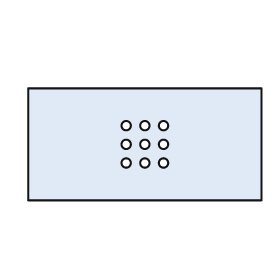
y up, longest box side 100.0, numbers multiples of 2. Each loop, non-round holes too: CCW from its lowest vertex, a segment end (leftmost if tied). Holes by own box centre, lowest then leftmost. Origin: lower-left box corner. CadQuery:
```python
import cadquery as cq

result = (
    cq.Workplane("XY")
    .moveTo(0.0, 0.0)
    .lineTo(100.0, 0.0)
    .lineTo(100.0, 48.0)
    .lineTo(0.0, 48.0)
    .close()
    .moveTo(42.0, 16.0)
    .circle(2.0)
    .moveTo(50.0, 16.0)
    .circle(2.0)
    .moveTo(58.0, 16.0)
    .circle(2.0)
    .moveTo(42.0, 24.0)
    .circle(2.0)
    .moveTo(50.0, 24.0)
    .circle(2.0)
    .moveTo(58.0, 24.0)
    .circle(2.0)
    .moveTo(42.0, 32.0)
    .circle(2.0)
    .moveTo(50.0, 32.0)
    .circle(2.0)
    .moveTo(58.0, 32.0)
    .circle(2.0)
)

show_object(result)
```